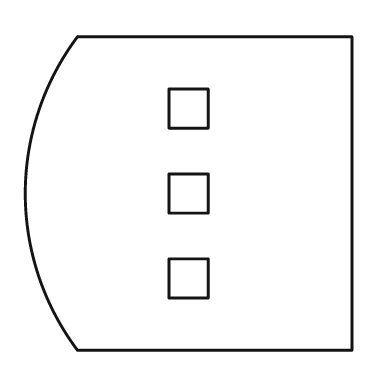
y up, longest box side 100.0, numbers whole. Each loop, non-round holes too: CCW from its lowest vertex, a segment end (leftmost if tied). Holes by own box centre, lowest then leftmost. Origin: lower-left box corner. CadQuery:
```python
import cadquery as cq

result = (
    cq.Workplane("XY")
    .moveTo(16.0, 0.0)
    .lineTo(100.0, 0.0)
    .lineTo(100.0, 96.0)
    .lineTo(16.0, 96.0)
    .threePointArc((0.0, 48.0), (16.0, 0.0))
    .close()
    .moveTo(44.0, 16.0)
    .lineTo(56.0, 16.0)
    .lineTo(56.0, 28.0)
    .lineTo(44.0, 28.0)
    .close()
    .moveTo(44.0, 42.0)
    .lineTo(56.0, 42.0)
    .lineTo(56.0, 54.0)
    .lineTo(44.0, 54.0)
    .close()
    .moveTo(44.0, 68.0)
    .lineTo(56.0, 68.0)
    .lineTo(56.0, 80.0)
    .lineTo(44.0, 80.0)
    .close()
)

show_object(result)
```